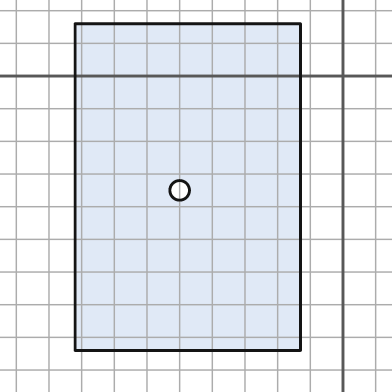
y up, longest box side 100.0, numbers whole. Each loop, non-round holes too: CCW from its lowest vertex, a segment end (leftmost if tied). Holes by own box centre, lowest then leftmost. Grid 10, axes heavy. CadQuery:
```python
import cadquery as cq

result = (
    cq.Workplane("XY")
    .moveTo(-82.0, -84.0)
    .lineTo(-13.0, -84.0)
    .lineTo(-13.0, 16.0)
    .lineTo(-82.0, 16.0)
    .close()
    .moveTo(-50.0, -35.0)
    .circle(3.0)
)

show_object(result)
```